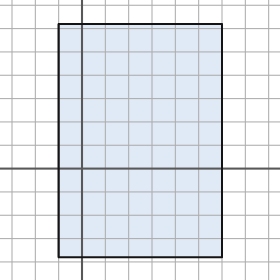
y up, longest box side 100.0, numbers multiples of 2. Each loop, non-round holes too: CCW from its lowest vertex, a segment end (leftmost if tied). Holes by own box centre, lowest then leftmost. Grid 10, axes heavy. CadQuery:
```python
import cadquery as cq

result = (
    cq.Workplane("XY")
    .moveTo(-10.0, -38.0)
    .lineTo(60.0, -38.0)
    .lineTo(60.0, 62.0)
    .lineTo(-10.0, 62.0)
    .close()
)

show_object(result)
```